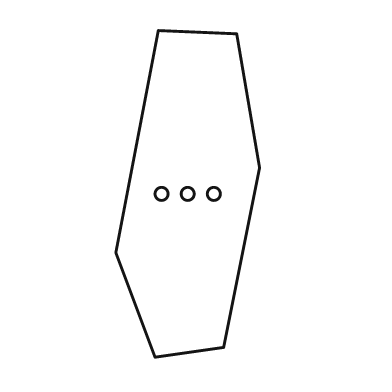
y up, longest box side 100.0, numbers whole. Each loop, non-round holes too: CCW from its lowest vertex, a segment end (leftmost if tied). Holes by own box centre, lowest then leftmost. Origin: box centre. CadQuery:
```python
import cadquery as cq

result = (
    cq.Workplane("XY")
    .moveTo(-10.0, -50.0)
    .lineTo(11.0, -47.0)
    .lineTo(22.0, 8.0)
    .lineTo(15.0, 49.0)
    .lineTo(-9.0, 50.0)
    .lineTo(-22.0, -18.0)
    .close()
    .moveTo(-8.0, 0.0)
    .circle(2.0)
    .moveTo(0.0, 0.0)
    .circle(2.0)
    .moveTo(8.0, 0.0)
    .circle(2.0)
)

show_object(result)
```